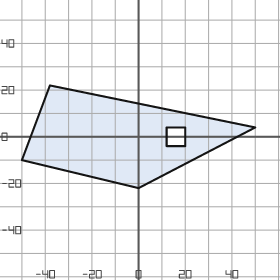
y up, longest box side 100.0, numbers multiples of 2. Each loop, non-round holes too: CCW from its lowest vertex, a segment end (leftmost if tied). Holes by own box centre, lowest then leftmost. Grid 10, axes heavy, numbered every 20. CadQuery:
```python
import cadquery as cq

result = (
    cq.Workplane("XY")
    .moveTo(0.0, -22.0)
    .lineTo(50.0, 4.0)
    .lineTo(-38.0, 22.0)
    .lineTo(-50.0, -10.0)
    .close()
    .moveTo(12.0, -4.0)
    .lineTo(20.0, -4.0)
    .lineTo(20.0, 4.0)
    .lineTo(12.0, 4.0)
    .close()
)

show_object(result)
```